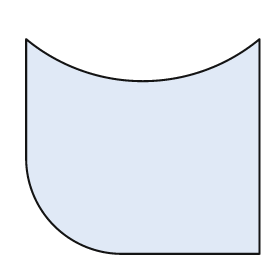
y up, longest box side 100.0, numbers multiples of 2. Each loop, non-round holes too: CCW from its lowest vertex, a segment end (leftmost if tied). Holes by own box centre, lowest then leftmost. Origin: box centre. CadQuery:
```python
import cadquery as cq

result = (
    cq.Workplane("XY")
    .moveTo(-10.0, -46.0)
    .lineTo(50.0, -46.0)
    .lineTo(50.0, 46.0)
    .threePointArc((0.0, 28.0), (-50.0, 46.0))
    .lineTo(-50.0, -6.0)
    .threePointArc((-38.0, -34.0), (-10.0, -46.0))
    .close()
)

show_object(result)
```